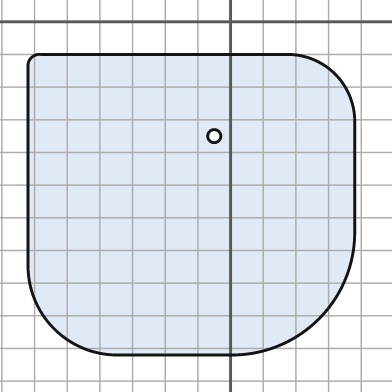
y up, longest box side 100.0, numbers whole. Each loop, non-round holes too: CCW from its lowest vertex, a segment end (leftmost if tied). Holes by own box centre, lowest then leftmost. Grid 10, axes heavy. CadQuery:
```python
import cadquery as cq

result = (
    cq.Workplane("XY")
    .moveTo(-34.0, -102.0)
    .lineTo(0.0, -102.0)
    .threePointArc((27.0, -91.0), (38.0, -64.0))
    .lineTo(38.0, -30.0)
    .threePointArc((32.0, -16.0), (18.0, -10.0))
    .lineTo(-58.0, -10.0)
    .threePointArc((-61.0, -11.0), (-62.0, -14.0))
    .lineTo(-62.0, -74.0)
    .threePointArc((-54.0, -94.0), (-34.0, -102.0))
    .close()
    .moveTo(-5.0, -35.0)
    .circle(2.0)
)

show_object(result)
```